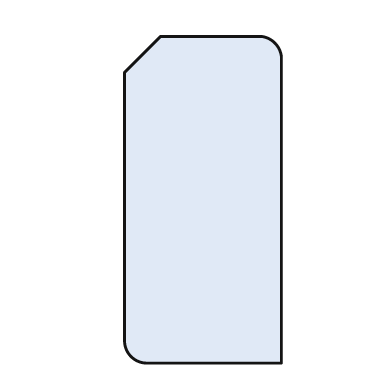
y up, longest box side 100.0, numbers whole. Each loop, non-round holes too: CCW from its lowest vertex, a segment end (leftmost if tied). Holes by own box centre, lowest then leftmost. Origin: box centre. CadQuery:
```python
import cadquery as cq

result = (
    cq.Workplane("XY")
    .moveTo(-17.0, -50.0)
    .lineTo(24.0, -50.0)
    .lineTo(24.0, 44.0)
    .threePointArc((22.0, 48.0), (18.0, 50.0))
    .lineTo(-13.0, 50.0)
    .lineTo(-24.0, 39.0)
    .lineTo(-24.0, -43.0)
    .threePointArc((-22.0, -48.0), (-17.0, -50.0))
    .close()
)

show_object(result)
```